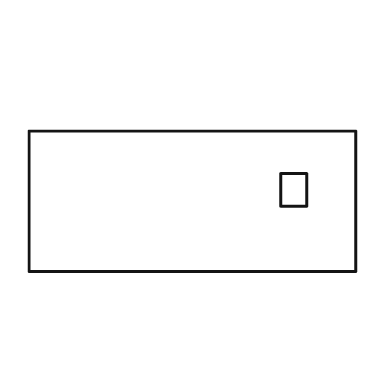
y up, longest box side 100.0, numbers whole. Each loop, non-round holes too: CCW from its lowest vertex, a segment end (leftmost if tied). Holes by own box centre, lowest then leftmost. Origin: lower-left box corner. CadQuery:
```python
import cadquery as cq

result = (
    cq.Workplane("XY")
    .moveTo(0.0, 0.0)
    .lineTo(100.0, 0.0)
    .lineTo(100.0, 43.0)
    .lineTo(0.0, 43.0)
    .close()
    .moveTo(77.0, 20.0)
    .lineTo(85.0, 20.0)
    .lineTo(85.0, 30.0)
    .lineTo(77.0, 30.0)
    .close()
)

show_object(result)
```